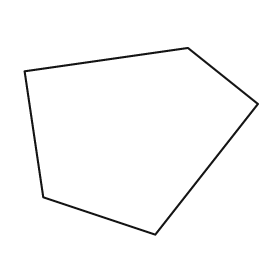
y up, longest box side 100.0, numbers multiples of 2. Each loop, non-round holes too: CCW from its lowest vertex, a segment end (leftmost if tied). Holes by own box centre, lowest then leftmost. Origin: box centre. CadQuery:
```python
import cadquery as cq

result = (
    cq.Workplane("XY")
    .moveTo(6.0, -40.0)
    .lineTo(50.0, 16.0)
    .lineTo(20.0, 40.0)
    .lineTo(-50.0, 30.0)
    .lineTo(-42.0, -24.0)
    .close()
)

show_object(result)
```